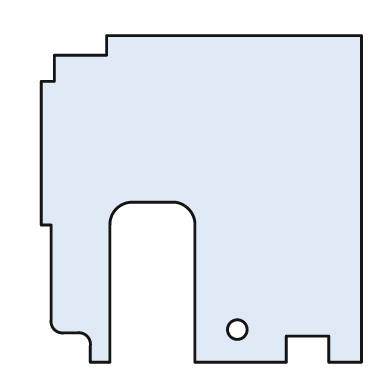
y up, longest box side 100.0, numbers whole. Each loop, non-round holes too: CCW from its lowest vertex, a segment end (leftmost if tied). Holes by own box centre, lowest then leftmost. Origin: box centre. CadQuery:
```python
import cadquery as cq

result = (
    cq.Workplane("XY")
    .moveTo(-34.0, -50.0)
    .lineTo(-28.0, -50.0)
    .lineTo(-28.0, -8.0)
    .threePointArc((-26.0, -3.0), (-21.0, -1.0))
    .lineTo(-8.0, -1.0)
    .threePointArc((-4.0, -3.0), (-2.0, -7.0))
    .lineTo(-2.0, -50.0)
    .lineTo(26.0, -50.0)
    .lineTo(26.0, -42.0)
    .lineTo(39.0, -42.0)
    .lineTo(39.0, -50.0)
    .lineTo(49.0, -50.0)
    .lineTo(49.0, 50.0)
    .lineTo(-29.0, 50.0)
    .lineTo(-29.0, 44.0)
    .lineTo(-45.0, 44.0)
    .lineTo(-45.0, 36.0)
    .lineTo(-49.0, 36.0)
    .lineTo(-49.0, -8.0)
    .lineTo(-46.0, -8.0)
    .lineTo(-46.0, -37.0)
    .threePointArc((-45.0, -40.0), (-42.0, -41.0))
    .lineTo(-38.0, -41.0)
    .threePointArc((-35.0, -42.0), (-34.0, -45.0))
    .close()
    .moveTo(11.0, -40.0)
    .circle(3.0)
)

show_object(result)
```